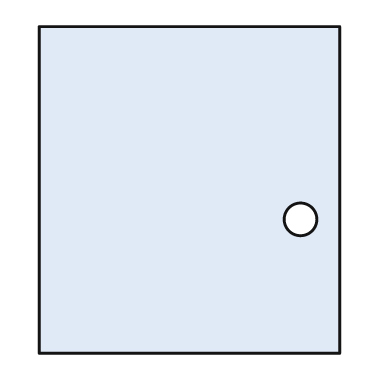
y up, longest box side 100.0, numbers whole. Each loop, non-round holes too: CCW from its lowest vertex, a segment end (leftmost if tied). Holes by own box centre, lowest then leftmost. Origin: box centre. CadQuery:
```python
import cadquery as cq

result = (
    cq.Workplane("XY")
    .moveTo(-46.0, -50.0)
    .lineTo(46.0, -50.0)
    .lineTo(46.0, 50.0)
    .lineTo(-46.0, 50.0)
    .close()
    .moveTo(34.0, -9.0)
    .circle(5.0)
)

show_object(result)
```